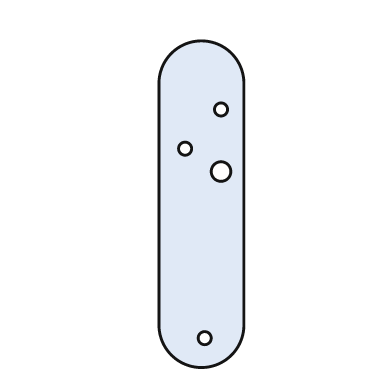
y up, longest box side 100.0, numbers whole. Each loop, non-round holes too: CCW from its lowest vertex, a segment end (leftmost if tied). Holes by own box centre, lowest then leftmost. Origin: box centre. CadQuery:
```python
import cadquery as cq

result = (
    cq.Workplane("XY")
    .moveTo(-13.0, -37.0)
    .threePointArc((0.0, -50.0), (13.0, -37.0))
    .lineTo(13.0, 37.0)
    .threePointArc((0.0, 50.0), (-13.0, 37.0))
    .close()
    .moveTo(1.0, -41.0)
    .circle(2.0)
    .moveTo(6.0, 10.0)
    .circle(3.0)
    .moveTo(-5.0, 17.0)
    .circle(2.0)
    .moveTo(6.0, 29.0)
    .circle(2.0)
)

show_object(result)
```